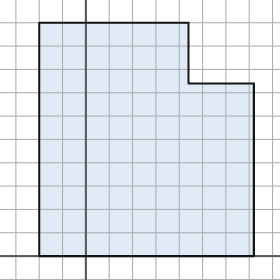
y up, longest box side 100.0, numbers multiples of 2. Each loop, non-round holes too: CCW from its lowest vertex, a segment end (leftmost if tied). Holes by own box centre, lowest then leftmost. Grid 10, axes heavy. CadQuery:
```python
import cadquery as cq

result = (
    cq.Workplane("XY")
    .moveTo(-20.0, 0.0)
    .lineTo(72.0, 0.0)
    .lineTo(72.0, 74.0)
    .lineTo(44.0, 74.0)
    .lineTo(44.0, 100.0)
    .lineTo(-20.0, 100.0)
    .close()
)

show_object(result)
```